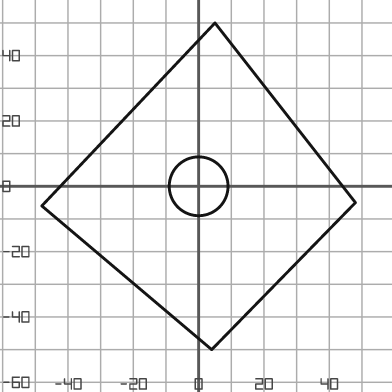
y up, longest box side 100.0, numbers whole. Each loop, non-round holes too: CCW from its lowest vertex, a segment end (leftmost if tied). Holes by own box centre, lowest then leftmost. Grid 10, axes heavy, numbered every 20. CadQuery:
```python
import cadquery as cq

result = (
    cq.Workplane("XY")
    .moveTo(4.0, -50.0)
    .lineTo(48.0, -5.0)
    .lineTo(5.0, 50.0)
    .lineTo(-48.0, -6.0)
    .close()
    .moveTo(0.0, 0.0)
    .circle(9.0)
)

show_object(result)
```